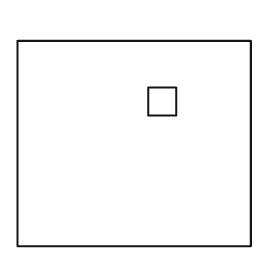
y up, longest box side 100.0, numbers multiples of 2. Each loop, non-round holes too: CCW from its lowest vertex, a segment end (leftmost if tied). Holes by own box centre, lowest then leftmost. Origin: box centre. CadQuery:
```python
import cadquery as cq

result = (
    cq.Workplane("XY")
    .moveTo(-50.0, -44.0)
    .lineTo(50.0, -44.0)
    .lineTo(50.0, 44.0)
    .lineTo(-50.0, 44.0)
    .close()
    .moveTo(6.0, 12.0)
    .lineTo(18.0, 12.0)
    .lineTo(18.0, 24.0)
    .lineTo(6.0, 24.0)
    .close()
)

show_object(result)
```